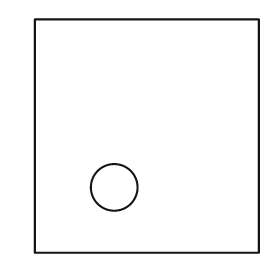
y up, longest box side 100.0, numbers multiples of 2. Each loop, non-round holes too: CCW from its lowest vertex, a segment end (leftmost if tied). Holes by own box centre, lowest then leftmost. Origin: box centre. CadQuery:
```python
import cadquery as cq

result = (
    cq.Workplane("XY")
    .moveTo(-48.0, -50.0)
    .lineTo(48.0, -50.0)
    .lineTo(48.0, 50.0)
    .lineTo(-48.0, 50.0)
    .close()
    .moveTo(-14.0, -22.0)
    .circle(10.0)
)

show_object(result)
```